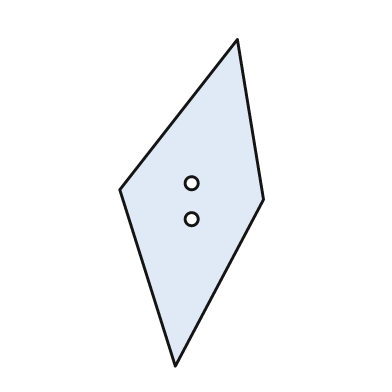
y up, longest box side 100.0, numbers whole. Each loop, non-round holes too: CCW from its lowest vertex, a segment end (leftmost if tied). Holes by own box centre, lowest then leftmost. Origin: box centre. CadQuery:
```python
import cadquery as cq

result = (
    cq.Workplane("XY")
    .moveTo(-5.0, -50.0)
    .lineTo(22.0, 1.0)
    .lineTo(14.0, 50.0)
    .lineTo(-22.0, 4.0)
    .close()
    .moveTo(0.0, -5.0)
    .circle(2.0)
    .moveTo(0.0, 6.0)
    .circle(2.0)
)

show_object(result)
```